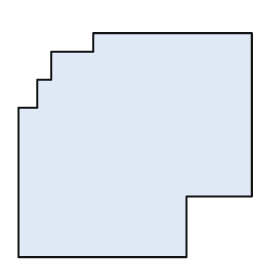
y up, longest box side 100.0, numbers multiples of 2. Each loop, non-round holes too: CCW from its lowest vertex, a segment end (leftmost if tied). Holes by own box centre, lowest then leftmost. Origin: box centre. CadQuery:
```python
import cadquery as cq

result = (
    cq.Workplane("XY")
    .moveTo(-50.0, -48.0)
    .lineTo(22.0, -48.0)
    .lineTo(22.0, -22.0)
    .lineTo(50.0, -22.0)
    .lineTo(50.0, 48.0)
    .lineTo(-18.0, 48.0)
    .lineTo(-18.0, 40.0)
    .lineTo(-36.0, 40.0)
    .lineTo(-36.0, 28.0)
    .lineTo(-42.0, 28.0)
    .lineTo(-42.0, 16.0)
    .lineTo(-50.0, 16.0)
    .close()
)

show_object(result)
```